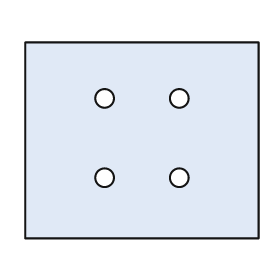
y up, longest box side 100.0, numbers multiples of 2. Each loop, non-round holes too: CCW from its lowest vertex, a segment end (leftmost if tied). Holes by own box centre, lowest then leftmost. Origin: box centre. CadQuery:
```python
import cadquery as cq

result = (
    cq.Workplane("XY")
    .moveTo(-50.0, -42.0)
    .lineTo(50.0, -42.0)
    .lineTo(50.0, 42.0)
    .lineTo(-50.0, 42.0)
    .close()
    .moveTo(-16.0, -16.0)
    .circle(4.0)
    .moveTo(16.0, -16.0)
    .circle(4.0)
    .moveTo(-16.0, 18.0)
    .circle(4.0)
    .moveTo(16.0, 18.0)
    .circle(4.0)
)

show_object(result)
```